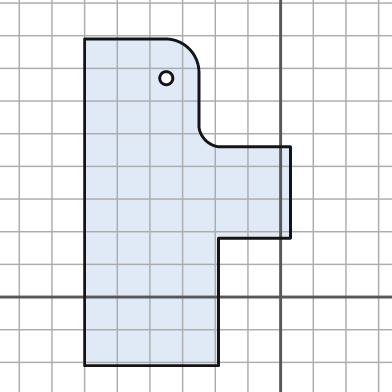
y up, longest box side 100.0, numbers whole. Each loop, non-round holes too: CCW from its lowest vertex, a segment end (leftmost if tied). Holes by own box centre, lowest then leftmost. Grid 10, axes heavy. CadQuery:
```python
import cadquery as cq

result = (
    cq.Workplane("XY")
    .moveTo(-60.0, -21.0)
    .lineTo(-19.0, -21.0)
    .lineTo(-19.0, 18.0)
    .lineTo(3.0, 18.0)
    .lineTo(3.0, 46.0)
    .lineTo(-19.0, 46.0)
    .threePointArc((-23.0, 48.0), (-25.0, 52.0))
    .lineTo(-25.0, 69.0)
    .threePointArc((-28.0, 76.0), (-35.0, 79.0))
    .lineTo(-60.0, 79.0)
    .close()
    .moveTo(-35.0, 67.0)
    .circle(2.0)
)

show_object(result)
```